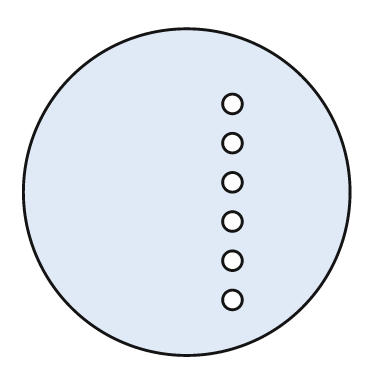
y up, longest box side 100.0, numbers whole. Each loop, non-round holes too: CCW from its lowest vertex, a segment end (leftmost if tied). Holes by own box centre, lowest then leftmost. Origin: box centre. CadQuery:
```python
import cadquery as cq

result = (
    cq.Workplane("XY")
    .moveTo(0.0, 0.0)
    .circle(50.0)
    .moveTo(14.0, -33.0)
    .circle(3.0)
    .moveTo(14.0, -21.0)
    .circle(3.0)
    .moveTo(14.0, -9.0)
    .circle(3.0)
    .moveTo(14.0, 3.0)
    .circle(3.0)
    .moveTo(14.0, 15.0)
    .circle(3.0)
    .moveTo(14.0, 27.0)
    .circle(3.0)
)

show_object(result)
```